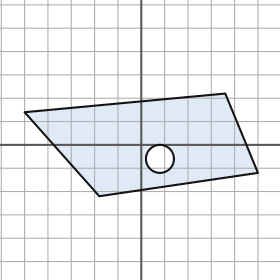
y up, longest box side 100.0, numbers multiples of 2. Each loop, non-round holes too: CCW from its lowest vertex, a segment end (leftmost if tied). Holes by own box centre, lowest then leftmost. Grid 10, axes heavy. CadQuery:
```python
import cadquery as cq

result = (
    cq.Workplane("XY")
    .moveTo(-18.0, -22.0)
    .lineTo(50.0, -12.0)
    .lineTo(36.0, 22.0)
    .lineTo(-50.0, 14.0)
    .close()
    .moveTo(8.0, -6.0)
    .circle(6.0)
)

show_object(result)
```